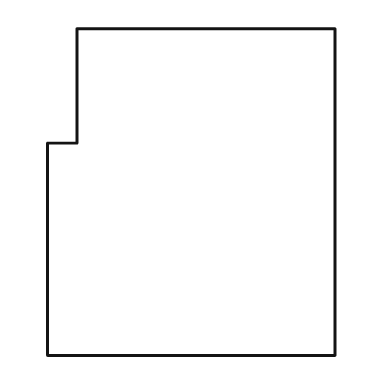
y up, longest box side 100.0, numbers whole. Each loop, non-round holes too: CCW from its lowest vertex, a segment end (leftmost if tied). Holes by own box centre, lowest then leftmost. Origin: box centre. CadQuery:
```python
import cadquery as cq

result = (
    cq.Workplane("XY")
    .moveTo(-44.0, -50.0)
    .lineTo(44.0, -50.0)
    .lineTo(44.0, 50.0)
    .lineTo(-35.0, 50.0)
    .lineTo(-35.0, 15.0)
    .lineTo(-44.0, 15.0)
    .close()
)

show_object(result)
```